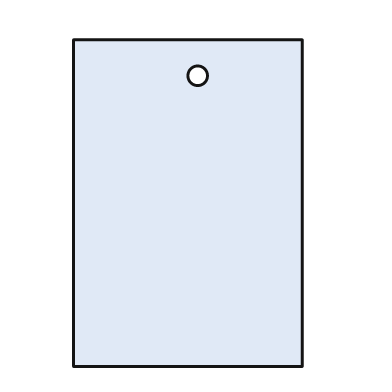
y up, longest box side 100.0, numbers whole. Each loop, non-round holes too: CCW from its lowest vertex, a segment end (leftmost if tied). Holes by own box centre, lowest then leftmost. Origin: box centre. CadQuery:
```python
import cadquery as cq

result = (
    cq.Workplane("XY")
    .moveTo(-35.0, -50.0)
    .lineTo(35.0, -50.0)
    .lineTo(35.0, 50.0)
    .lineTo(-35.0, 50.0)
    .close()
    .moveTo(3.0, 39.0)
    .circle(3.0)
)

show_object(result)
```